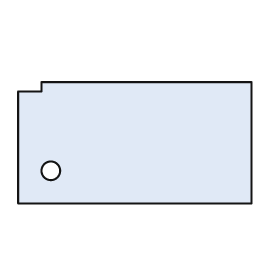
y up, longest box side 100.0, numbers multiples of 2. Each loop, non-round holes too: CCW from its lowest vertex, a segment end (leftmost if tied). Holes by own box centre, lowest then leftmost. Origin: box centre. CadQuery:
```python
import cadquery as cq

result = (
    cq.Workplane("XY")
    .moveTo(-50.0, -26.0)
    .lineTo(50.0, -26.0)
    .lineTo(50.0, 26.0)
    .lineTo(-40.0, 26.0)
    .lineTo(-40.0, 22.0)
    .lineTo(-50.0, 22.0)
    .close()
    .moveTo(-36.0, -12.0)
    .circle(4.0)
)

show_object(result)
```